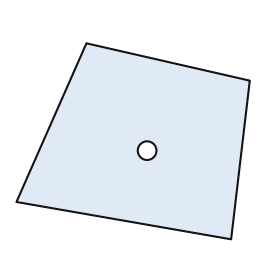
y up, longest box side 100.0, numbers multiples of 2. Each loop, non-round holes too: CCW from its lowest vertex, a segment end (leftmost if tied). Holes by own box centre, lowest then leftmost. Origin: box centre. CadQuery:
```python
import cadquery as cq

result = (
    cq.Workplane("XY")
    .moveTo(42.0, -42.0)
    .lineTo(50.0, 26.0)
    .lineTo(-20.0, 42.0)
    .lineTo(-50.0, -26.0)
    .close()
    .moveTo(6.0, -4.0)
    .circle(4.0)
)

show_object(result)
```